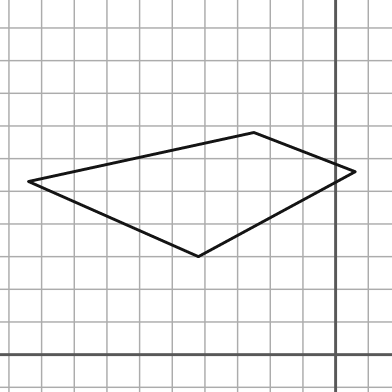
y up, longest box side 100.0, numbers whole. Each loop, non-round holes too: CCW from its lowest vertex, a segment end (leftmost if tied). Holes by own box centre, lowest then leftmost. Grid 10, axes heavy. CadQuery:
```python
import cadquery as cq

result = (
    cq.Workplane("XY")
    .moveTo(-42.0, 30.0)
    .lineTo(6.0, 56.0)
    .lineTo(-25.0, 68.0)
    .lineTo(-94.0, 53.0)
    .close()
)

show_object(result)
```